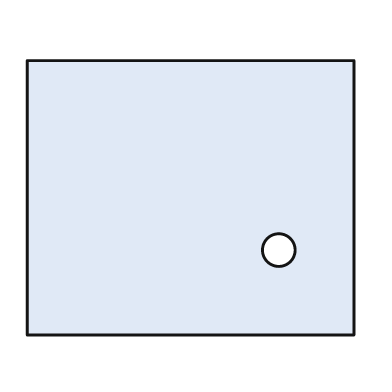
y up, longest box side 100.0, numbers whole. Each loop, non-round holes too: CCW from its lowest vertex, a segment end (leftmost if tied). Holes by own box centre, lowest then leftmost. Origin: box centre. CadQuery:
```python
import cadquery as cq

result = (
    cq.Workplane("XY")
    .moveTo(-50.0, -42.0)
    .lineTo(50.0, -42.0)
    .lineTo(50.0, 42.0)
    .lineTo(-50.0, 42.0)
    .close()
    .moveTo(27.0, -16.0)
    .circle(5.0)
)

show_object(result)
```